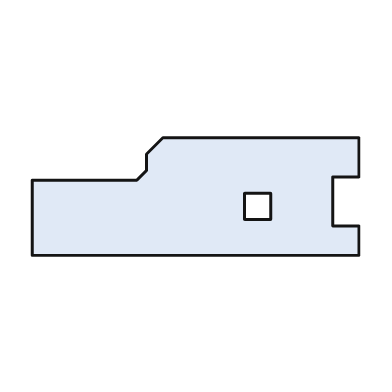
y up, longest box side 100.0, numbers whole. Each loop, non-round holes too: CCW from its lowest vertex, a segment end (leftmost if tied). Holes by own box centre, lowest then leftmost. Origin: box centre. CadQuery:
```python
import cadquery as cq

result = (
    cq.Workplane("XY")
    .moveTo(-50.0, -18.0)
    .lineTo(50.0, -18.0)
    .lineTo(50.0, -9.0)
    .lineTo(42.0, -9.0)
    .lineTo(42.0, 6.0)
    .lineTo(50.0, 6.0)
    .lineTo(50.0, 18.0)
    .lineTo(-10.0, 18.0)
    .lineTo(-15.0, 13.0)
    .lineTo(-15.0, 8.0)
    .lineTo(-18.0, 5.0)
    .lineTo(-50.0, 5.0)
    .close()
    .moveTo(15.0, -7.0)
    .lineTo(23.0, -7.0)
    .lineTo(23.0, 1.0)
    .lineTo(15.0, 1.0)
    .close()
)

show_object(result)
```